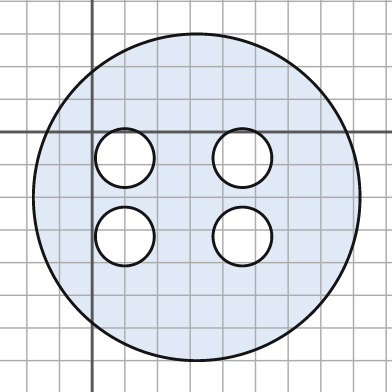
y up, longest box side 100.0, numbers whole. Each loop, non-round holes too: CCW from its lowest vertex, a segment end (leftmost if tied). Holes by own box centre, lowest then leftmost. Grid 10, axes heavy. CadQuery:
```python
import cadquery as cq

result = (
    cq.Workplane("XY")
    .moveTo(32.0, -20.0)
    .circle(50.0)
    .moveTo(10.0, -32.0)
    .circle(9.0)
    .moveTo(46.0, -32.0)
    .circle(9.0)
    .moveTo(10.0, -8.0)
    .circle(9.0)
    .moveTo(46.0, -8.0)
    .circle(9.0)
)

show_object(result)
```